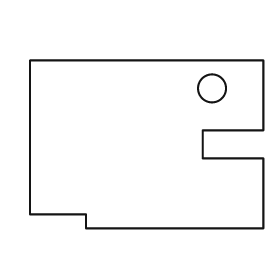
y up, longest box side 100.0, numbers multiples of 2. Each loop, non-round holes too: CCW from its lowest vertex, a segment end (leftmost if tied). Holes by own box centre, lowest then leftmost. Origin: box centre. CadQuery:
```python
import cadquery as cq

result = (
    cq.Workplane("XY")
    .moveTo(-26.0, -36.0)
    .lineTo(50.0, -36.0)
    .lineTo(50.0, -6.0)
    .lineTo(24.0, -6.0)
    .lineTo(24.0, 6.0)
    .lineTo(50.0, 6.0)
    .lineTo(50.0, 36.0)
    .lineTo(-50.0, 36.0)
    .lineTo(-50.0, -30.0)
    .lineTo(-26.0, -30.0)
    .close()
    .moveTo(28.0, 24.0)
    .circle(6.0)
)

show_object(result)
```